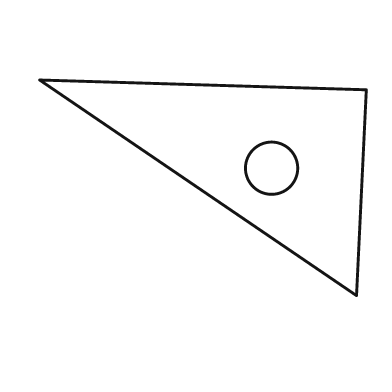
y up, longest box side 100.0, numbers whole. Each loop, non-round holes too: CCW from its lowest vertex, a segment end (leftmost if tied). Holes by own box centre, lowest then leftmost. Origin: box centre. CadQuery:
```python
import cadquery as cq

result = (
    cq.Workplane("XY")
    .moveTo(47.0, -33.0)
    .lineTo(50.0, 30.0)
    .lineTo(-50.0, 33.0)
    .close()
    .moveTo(21.0, 6.0)
    .circle(8.0)
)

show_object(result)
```